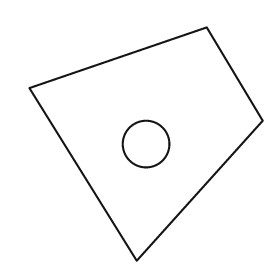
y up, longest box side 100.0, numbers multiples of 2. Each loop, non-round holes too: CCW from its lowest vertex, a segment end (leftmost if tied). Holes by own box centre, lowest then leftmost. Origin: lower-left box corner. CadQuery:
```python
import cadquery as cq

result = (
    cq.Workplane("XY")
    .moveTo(46.0, 0.0)
    .lineTo(100.0, 60.0)
    .lineTo(76.0, 100.0)
    .lineTo(0.0, 74.0)
    .close()
    .moveTo(50.0, 50.0)
    .circle(10.0)
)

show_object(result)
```